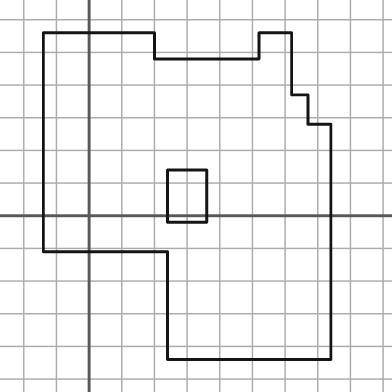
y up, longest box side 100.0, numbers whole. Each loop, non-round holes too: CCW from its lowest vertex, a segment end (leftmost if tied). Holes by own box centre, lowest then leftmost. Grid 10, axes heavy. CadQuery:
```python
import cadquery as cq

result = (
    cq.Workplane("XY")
    .moveTo(24.0, -44.0)
    .lineTo(74.0, -44.0)
    .lineTo(74.0, 28.0)
    .lineTo(67.0, 28.0)
    .lineTo(67.0, 37.0)
    .lineTo(62.0, 37.0)
    .lineTo(62.0, 56.0)
    .lineTo(52.0, 56.0)
    .lineTo(52.0, 48.0)
    .lineTo(20.0, 48.0)
    .lineTo(20.0, 56.0)
    .lineTo(-14.0, 56.0)
    .lineTo(-14.0, -11.0)
    .lineTo(24.0, -11.0)
    .close()
    .moveTo(24.0, -2.0)
    .lineTo(36.0, -2.0)
    .lineTo(36.0, 14.0)
    .lineTo(24.0, 14.0)
    .close()
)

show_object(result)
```